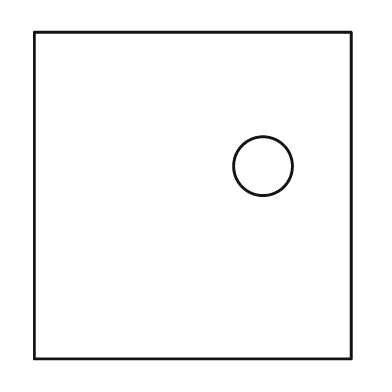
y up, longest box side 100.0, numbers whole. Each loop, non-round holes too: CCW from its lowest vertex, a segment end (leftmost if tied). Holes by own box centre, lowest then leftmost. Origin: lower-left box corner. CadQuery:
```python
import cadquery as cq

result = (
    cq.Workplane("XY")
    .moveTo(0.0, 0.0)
    .lineTo(97.0, 0.0)
    .lineTo(97.0, 100.0)
    .lineTo(0.0, 100.0)
    .close()
    .moveTo(70.0, 59.0)
    .circle(9.0)
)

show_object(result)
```